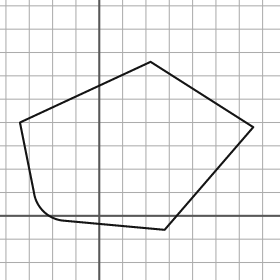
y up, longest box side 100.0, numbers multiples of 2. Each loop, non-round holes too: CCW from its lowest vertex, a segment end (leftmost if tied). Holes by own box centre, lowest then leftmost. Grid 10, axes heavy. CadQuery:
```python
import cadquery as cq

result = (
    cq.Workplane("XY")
    .moveTo(28.0, -6.0)
    .lineTo(66.0, 38.0)
    .lineTo(22.0, 66.0)
    .lineTo(-34.0, 40.0)
    .lineTo(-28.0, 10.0)
    .threePointArc((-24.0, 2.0), (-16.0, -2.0))
    .close()
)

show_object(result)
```